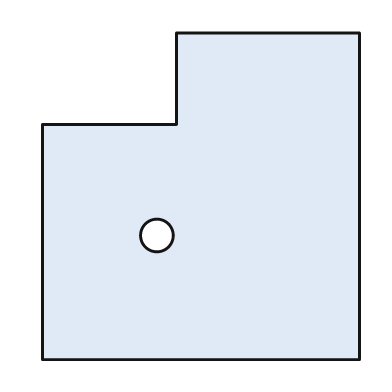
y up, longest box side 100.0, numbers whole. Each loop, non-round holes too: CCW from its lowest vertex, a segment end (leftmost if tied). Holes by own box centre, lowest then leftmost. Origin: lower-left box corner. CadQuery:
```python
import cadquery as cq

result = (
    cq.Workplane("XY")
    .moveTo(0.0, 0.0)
    .lineTo(97.0, 0.0)
    .lineTo(97.0, 100.0)
    .lineTo(41.0, 100.0)
    .lineTo(41.0, 72.0)
    .lineTo(0.0, 72.0)
    .close()
    .moveTo(35.0, 38.0)
    .circle(5.0)
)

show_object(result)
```